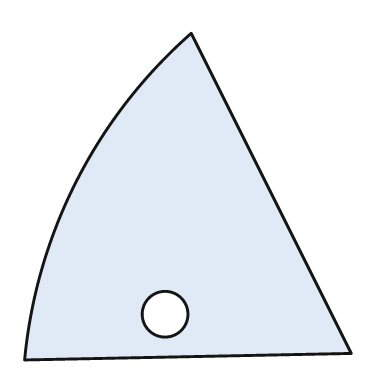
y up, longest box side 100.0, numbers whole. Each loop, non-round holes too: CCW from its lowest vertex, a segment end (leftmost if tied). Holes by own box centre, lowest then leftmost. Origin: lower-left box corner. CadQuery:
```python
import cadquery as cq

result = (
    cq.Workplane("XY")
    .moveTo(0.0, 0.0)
    .lineTo(100.0, 2.0)
    .lineTo(51.0, 100.0)
    .threePointArc((16.0, 55.0), (0.0, 0.0))
    .close()
    .moveTo(43.0, 14.0)
    .circle(7.0)
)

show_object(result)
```